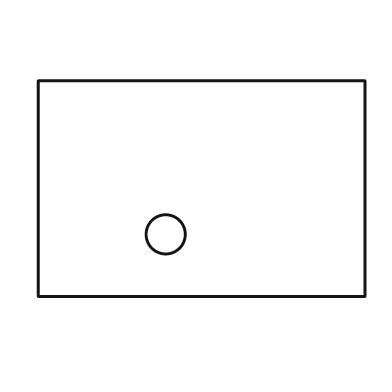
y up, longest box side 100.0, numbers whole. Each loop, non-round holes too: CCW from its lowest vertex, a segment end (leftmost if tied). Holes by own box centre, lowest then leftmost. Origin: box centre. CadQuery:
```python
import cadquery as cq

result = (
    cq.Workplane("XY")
    .moveTo(-50.0, -33.0)
    .lineTo(50.0, -33.0)
    .lineTo(50.0, 33.0)
    .lineTo(-50.0, 33.0)
    .close()
    .moveTo(-11.0, -14.0)
    .circle(6.0)
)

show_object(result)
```